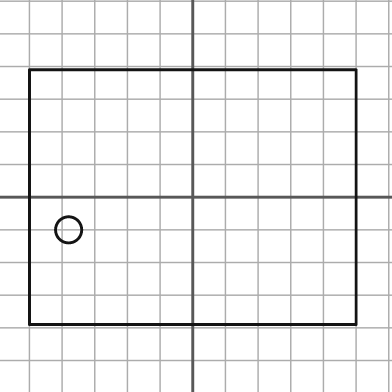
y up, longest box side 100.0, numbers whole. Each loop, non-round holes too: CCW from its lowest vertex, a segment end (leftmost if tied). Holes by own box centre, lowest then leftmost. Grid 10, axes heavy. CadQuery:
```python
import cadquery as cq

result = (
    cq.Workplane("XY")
    .moveTo(-50.0, -39.0)
    .lineTo(50.0, -39.0)
    .lineTo(50.0, 39.0)
    .lineTo(-50.0, 39.0)
    .close()
    .moveTo(-38.0, -10.0)
    .circle(4.0)
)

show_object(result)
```